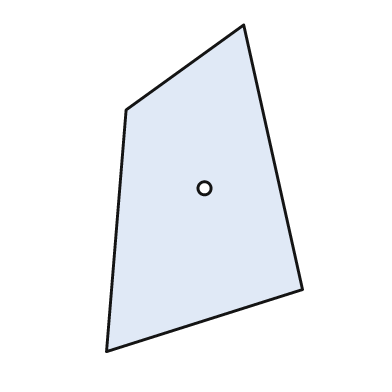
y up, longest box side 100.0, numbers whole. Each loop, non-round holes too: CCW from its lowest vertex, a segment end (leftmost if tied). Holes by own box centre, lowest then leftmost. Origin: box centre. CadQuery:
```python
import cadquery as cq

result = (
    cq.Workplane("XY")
    .moveTo(-30.0, -50.0)
    .lineTo(30.0, -31.0)
    .lineTo(12.0, 50.0)
    .lineTo(-24.0, 24.0)
    .close()
    .moveTo(0.0, 0.0)
    .circle(2.0)
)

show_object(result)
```